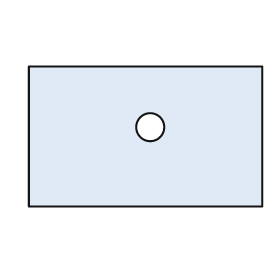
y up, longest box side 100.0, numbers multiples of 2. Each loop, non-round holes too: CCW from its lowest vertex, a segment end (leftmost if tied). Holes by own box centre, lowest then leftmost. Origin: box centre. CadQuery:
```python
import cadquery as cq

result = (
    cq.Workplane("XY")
    .moveTo(-50.0, -30.0)
    .lineTo(50.0, -30.0)
    .lineTo(50.0, 30.0)
    .lineTo(-50.0, 30.0)
    .close()
    .moveTo(2.0, 4.0)
    .circle(6.0)
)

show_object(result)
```